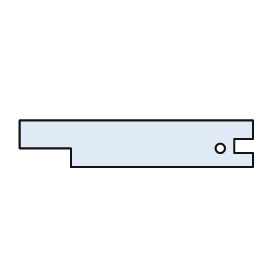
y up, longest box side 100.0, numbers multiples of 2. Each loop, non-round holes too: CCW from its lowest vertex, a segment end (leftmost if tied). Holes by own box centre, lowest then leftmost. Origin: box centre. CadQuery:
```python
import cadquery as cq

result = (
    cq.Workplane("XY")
    .moveTo(-28.0, -10.0)
    .lineTo(50.0, -10.0)
    .lineTo(50.0, -4.0)
    .lineTo(42.0, -4.0)
    .lineTo(42.0, 2.0)
    .lineTo(50.0, 2.0)
    .lineTo(50.0, 10.0)
    .lineTo(-50.0, 10.0)
    .lineTo(-50.0, -2.0)
    .lineTo(-28.0, -2.0)
    .close()
    .moveTo(36.0, -2.0)
    .circle(2.0)
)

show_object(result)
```